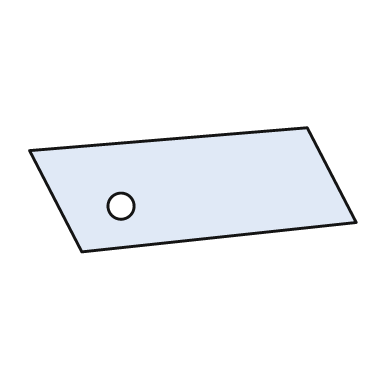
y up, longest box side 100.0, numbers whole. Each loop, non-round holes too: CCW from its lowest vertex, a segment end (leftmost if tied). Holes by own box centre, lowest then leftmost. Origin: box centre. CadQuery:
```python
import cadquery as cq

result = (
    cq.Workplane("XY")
    .moveTo(-34.0, -19.0)
    .lineTo(50.0, -10.0)
    .lineTo(35.0, 19.0)
    .lineTo(-50.0, 12.0)
    .close()
    .moveTo(-22.0, -5.0)
    .circle(4.0)
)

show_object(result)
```